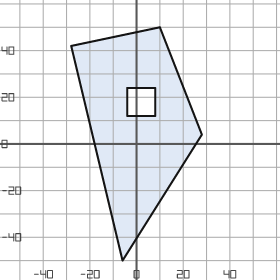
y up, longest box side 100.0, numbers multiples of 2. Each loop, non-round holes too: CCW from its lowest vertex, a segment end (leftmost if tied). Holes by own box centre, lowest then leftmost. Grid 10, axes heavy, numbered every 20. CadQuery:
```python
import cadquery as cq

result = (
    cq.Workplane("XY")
    .moveTo(-6.0, -50.0)
    .lineTo(28.0, 4.0)
    .lineTo(10.0, 50.0)
    .lineTo(-28.0, 42.0)
    .close()
    .moveTo(-4.0, 12.0)
    .lineTo(8.0, 12.0)
    .lineTo(8.0, 24.0)
    .lineTo(-4.0, 24.0)
    .close()
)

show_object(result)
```